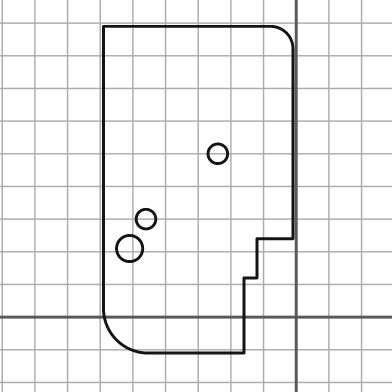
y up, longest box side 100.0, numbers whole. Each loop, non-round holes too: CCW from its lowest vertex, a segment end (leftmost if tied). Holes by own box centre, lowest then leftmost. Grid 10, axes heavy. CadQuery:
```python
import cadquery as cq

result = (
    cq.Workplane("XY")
    .moveTo(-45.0, -11.0)
    .lineTo(-16.0, -11.0)
    .lineTo(-16.0, 12.0)
    .lineTo(-12.0, 12.0)
    .lineTo(-12.0, 24.0)
    .lineTo(-1.0, 24.0)
    .lineTo(-1.0, 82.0)
    .threePointArc((-3.0, 87.0), (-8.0, 89.0))
    .lineTo(-59.0, 89.0)
    .lineTo(-59.0, 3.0)
    .threePointArc((-55.0, -7.0), (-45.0, -11.0))
    .close()
    .moveTo(-51.0, 21.0)
    .circle(4.0)
    .moveTo(-46.0, 30.0)
    .circle(3.0)
    .moveTo(-24.0, 50.0)
    .circle(3.0)
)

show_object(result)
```